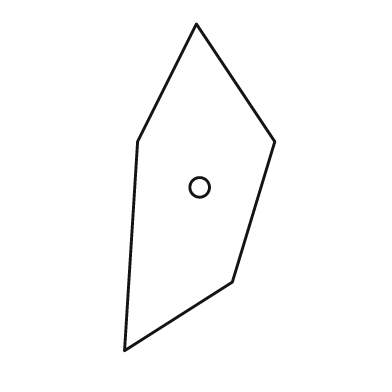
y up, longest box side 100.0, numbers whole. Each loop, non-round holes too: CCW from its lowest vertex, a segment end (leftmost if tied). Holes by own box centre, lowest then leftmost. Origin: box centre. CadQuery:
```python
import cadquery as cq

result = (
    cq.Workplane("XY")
    .moveTo(-23.0, -50.0)
    .lineTo(10.0, -29.0)
    .lineTo(23.0, 14.0)
    .lineTo(-1.0, 50.0)
    .lineTo(-19.0, 14.0)
    .close()
    .moveTo(0.0, 0.0)
    .circle(3.0)
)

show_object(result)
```